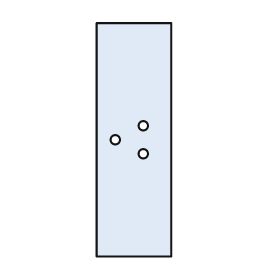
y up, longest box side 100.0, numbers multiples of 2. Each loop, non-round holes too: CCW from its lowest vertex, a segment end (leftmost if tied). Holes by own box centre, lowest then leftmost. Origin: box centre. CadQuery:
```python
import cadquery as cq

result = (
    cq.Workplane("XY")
    .moveTo(-16.0, -50.0)
    .lineTo(16.0, -50.0)
    .lineTo(16.0, 50.0)
    .lineTo(-16.0, 50.0)
    .close()
    .moveTo(4.0, -6.0)
    .circle(2.0)
    .moveTo(-8.0, 0.0)
    .circle(2.0)
    .moveTo(4.0, 6.0)
    .circle(2.0)
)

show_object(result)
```